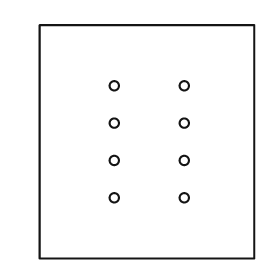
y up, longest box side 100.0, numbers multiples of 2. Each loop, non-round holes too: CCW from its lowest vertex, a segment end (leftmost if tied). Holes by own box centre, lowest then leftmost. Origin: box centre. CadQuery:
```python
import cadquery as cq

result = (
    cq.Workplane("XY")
    .moveTo(-46.0, -50.0)
    .lineTo(46.0, -50.0)
    .lineTo(46.0, 50.0)
    .lineTo(-46.0, 50.0)
    .close()
    .moveTo(-14.0, -24.0)
    .circle(2.0)
    .moveTo(16.0, -24.0)
    .circle(2.0)
    .moveTo(-14.0, -8.0)
    .circle(2.0)
    .moveTo(16.0, -8.0)
    .circle(2.0)
    .moveTo(-14.0, 8.0)
    .circle(2.0)
    .moveTo(16.0, 8.0)
    .circle(2.0)
    .moveTo(-14.0, 24.0)
    .circle(2.0)
    .moveTo(16.0, 24.0)
    .circle(2.0)
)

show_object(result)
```